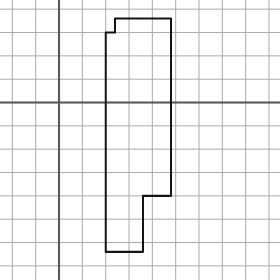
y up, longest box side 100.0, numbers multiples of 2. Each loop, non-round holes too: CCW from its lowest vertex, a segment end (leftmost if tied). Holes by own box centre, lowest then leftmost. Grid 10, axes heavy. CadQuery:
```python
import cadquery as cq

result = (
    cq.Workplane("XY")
    .moveTo(20.0, -64.0)
    .lineTo(36.0, -64.0)
    .lineTo(36.0, -40.0)
    .lineTo(48.0, -40.0)
    .lineTo(48.0, 36.0)
    .lineTo(24.0, 36.0)
    .lineTo(24.0, 30.0)
    .lineTo(20.0, 30.0)
    .close()
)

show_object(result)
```